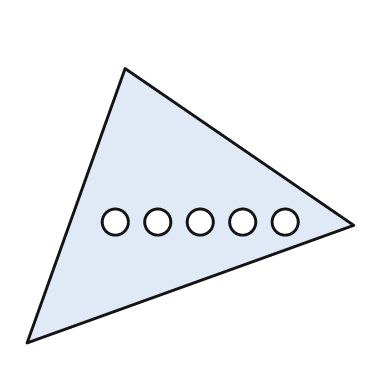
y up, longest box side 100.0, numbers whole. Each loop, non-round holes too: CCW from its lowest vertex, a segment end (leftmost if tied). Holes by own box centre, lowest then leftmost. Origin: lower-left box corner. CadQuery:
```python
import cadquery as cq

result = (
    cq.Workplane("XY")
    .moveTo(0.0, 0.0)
    .lineTo(100.0, 36.0)
    .lineTo(30.0, 84.0)
    .close()
    .moveTo(27.0, 37.0)
    .circle(4.0)
    .moveTo(40.0, 37.0)
    .circle(4.0)
    .moveTo(53.0, 37.0)
    .circle(4.0)
    .moveTo(66.0, 37.0)
    .circle(4.0)
    .moveTo(79.0, 37.0)
    .circle(4.0)
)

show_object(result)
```